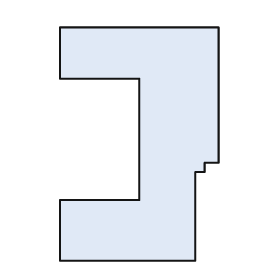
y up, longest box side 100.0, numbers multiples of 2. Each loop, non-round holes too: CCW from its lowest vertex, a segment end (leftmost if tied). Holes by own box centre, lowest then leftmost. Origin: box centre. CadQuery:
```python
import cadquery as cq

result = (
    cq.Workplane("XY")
    .moveTo(-34.0, -50.0)
    .lineTo(24.0, -50.0)
    .lineTo(24.0, -12.0)
    .lineTo(28.0, -12.0)
    .lineTo(28.0, -8.0)
    .lineTo(34.0, -8.0)
    .lineTo(34.0, 50.0)
    .lineTo(-34.0, 50.0)
    .lineTo(-34.0, 28.0)
    .lineTo(0.0, 28.0)
    .lineTo(0.0, -24.0)
    .lineTo(-34.0, -24.0)
    .close()
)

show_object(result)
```